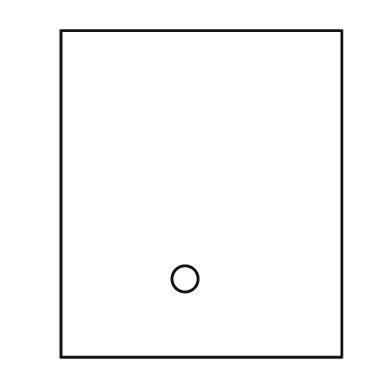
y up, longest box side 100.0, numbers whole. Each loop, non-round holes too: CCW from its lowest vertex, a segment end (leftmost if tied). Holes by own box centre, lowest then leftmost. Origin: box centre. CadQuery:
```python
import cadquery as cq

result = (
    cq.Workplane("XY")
    .moveTo(-43.0, -50.0)
    .lineTo(43.0, -50.0)
    .lineTo(43.0, 50.0)
    .lineTo(-43.0, 50.0)
    .close()
    .moveTo(-5.0, -26.0)
    .circle(4.0)
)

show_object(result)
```